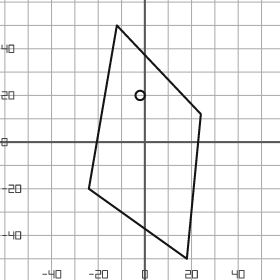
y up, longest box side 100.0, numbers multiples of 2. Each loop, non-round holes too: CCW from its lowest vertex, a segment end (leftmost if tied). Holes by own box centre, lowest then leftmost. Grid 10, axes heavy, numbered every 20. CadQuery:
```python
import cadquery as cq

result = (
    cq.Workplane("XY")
    .moveTo(18.0, -50.0)
    .lineTo(24.0, 12.0)
    .lineTo(-12.0, 50.0)
    .lineTo(-24.0, -20.0)
    .close()
    .moveTo(-2.0, 20.0)
    .circle(2.0)
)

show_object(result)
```